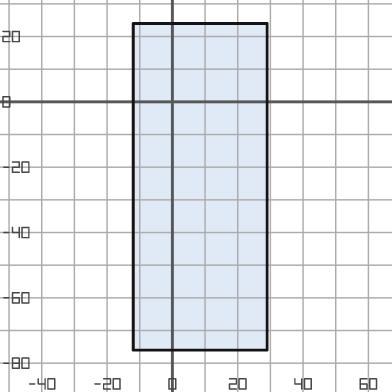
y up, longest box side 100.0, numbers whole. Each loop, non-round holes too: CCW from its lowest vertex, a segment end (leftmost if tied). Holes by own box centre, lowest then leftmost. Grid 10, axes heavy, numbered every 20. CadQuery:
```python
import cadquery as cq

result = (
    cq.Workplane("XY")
    .moveTo(-12.0, -76.0)
    .lineTo(29.0, -76.0)
    .lineTo(29.0, 24.0)
    .lineTo(-12.0, 24.0)
    .close()
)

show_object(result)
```